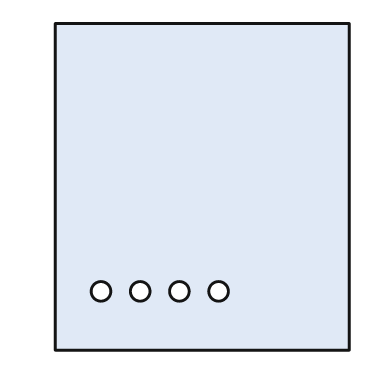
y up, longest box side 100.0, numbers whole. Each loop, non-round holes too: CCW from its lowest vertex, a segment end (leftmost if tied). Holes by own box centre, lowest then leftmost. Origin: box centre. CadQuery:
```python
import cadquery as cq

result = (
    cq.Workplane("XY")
    .moveTo(-45.0, -50.0)
    .lineTo(45.0, -50.0)
    .lineTo(45.0, 50.0)
    .lineTo(-45.0, 50.0)
    .close()
    .moveTo(-31.0, -32.0)
    .circle(3.0)
    .moveTo(-19.0, -32.0)
    .circle(3.0)
    .moveTo(-7.0, -32.0)
    .circle(3.0)
    .moveTo(5.0, -32.0)
    .circle(3.0)
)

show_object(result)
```